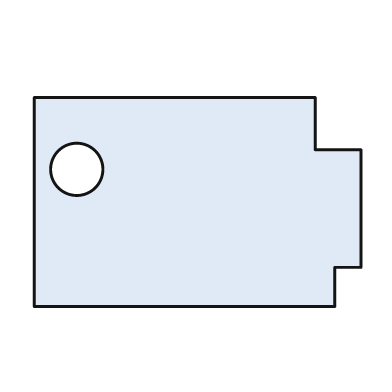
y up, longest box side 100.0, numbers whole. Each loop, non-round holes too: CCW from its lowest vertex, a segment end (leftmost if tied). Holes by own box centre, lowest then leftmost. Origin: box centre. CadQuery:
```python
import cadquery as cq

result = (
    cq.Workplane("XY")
    .moveTo(-50.0, -32.0)
    .lineTo(42.0, -32.0)
    .lineTo(42.0, -20.0)
    .lineTo(50.0, -20.0)
    .lineTo(50.0, 16.0)
    .lineTo(36.0, 16.0)
    .lineTo(36.0, 32.0)
    .lineTo(-50.0, 32.0)
    .close()
    .moveTo(-37.0, 10.0)
    .circle(8.0)
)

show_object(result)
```